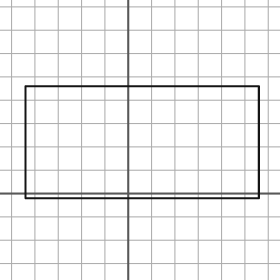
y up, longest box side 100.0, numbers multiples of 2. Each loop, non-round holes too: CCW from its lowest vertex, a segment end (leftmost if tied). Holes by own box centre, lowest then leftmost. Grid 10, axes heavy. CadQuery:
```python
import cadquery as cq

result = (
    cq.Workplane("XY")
    .moveTo(-44.0, -2.0)
    .lineTo(56.0, -2.0)
    .lineTo(56.0, 46.0)
    .lineTo(-44.0, 46.0)
    .close()
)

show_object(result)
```